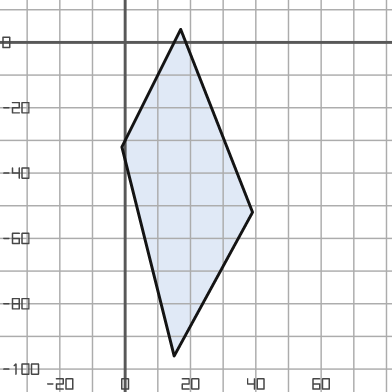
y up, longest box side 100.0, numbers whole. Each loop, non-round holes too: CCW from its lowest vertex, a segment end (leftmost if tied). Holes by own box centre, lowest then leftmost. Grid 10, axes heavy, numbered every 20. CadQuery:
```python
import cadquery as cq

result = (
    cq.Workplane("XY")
    .moveTo(15.0, -96.0)
    .lineTo(39.0, -52.0)
    .lineTo(17.0, 4.0)
    .lineTo(-1.0, -32.0)
    .close()
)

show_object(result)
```